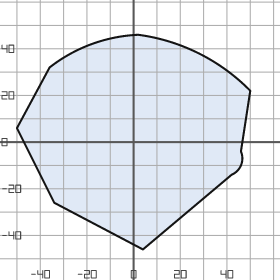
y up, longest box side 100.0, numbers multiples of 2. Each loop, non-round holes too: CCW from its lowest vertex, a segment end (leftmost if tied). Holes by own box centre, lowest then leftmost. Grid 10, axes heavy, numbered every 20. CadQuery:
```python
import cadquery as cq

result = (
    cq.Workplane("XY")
    .moveTo(4.0, -46.0)
    .lineTo(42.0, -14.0)
    .threePointArc((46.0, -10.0), (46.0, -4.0))
    .lineTo(50.0, 22.0)
    .threePointArc((28.0, 38.0), (2.0, 46.0))
    .threePointArc((-18.0, 42.0), (-36.0, 32.0))
    .lineTo(-50.0, 6.0)
    .lineTo(-34.0, -26.0)
    .close()
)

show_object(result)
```